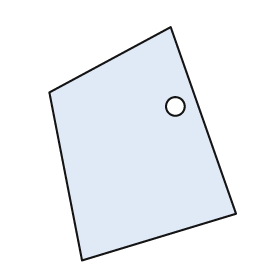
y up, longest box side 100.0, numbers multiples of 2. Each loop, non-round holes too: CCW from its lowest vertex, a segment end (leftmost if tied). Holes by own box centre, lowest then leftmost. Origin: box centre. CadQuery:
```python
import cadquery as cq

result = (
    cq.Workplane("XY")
    .moveTo(-26.0, -50.0)
    .lineTo(40.0, -30.0)
    .lineTo(12.0, 50.0)
    .lineTo(-40.0, 22.0)
    .close()
    .moveTo(14.0, 16.0)
    .circle(4.0)
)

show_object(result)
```